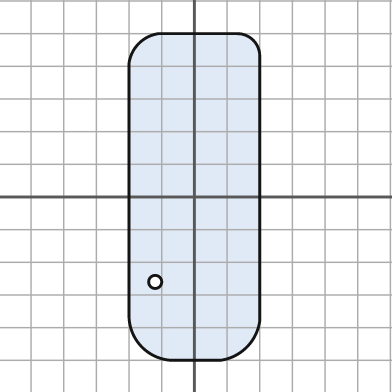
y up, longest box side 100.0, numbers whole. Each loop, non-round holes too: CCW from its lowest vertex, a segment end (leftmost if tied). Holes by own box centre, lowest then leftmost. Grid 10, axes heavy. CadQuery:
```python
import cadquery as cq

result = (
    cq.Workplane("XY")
    .moveTo(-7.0, -50.0)
    .lineTo(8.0, -50.0)
    .threePointArc((16.0, -46.0), (20.0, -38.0))
    .lineTo(20.0, 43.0)
    .threePointArc((18.0, 48.0), (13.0, 50.0))
    .lineTo(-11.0, 50.0)
    .threePointArc((-17.0, 47.0), (-20.0, 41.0))
    .lineTo(-20.0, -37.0)
    .threePointArc((-16.0, -46.0), (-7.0, -50.0))
    .close()
    .moveTo(-12.0, -26.0)
    .circle(2.0)
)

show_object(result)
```